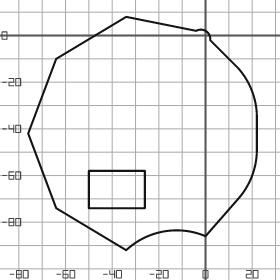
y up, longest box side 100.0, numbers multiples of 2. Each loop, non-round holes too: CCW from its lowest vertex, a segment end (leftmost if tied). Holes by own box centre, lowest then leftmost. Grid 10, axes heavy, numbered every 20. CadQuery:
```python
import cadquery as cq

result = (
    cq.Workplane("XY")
    .moveTo(-34.0, -92.0)
    .threePointArc((-18.0, -84.0), (0.0, -86.0))
    .lineTo(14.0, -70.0)
    .threePointArc((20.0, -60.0), (22.0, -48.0))
    .lineTo(22.0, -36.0)
    .threePointArc((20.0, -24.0), (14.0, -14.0))
    .lineTo(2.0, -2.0)
    .threePointArc((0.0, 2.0), (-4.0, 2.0))
    .lineTo(-34.0, 8.0)
    .lineTo(-64.0, -10.0)
    .lineTo(-76.0, -42.0)
    .lineTo(-64.0, -74.0)
    .close()
    .moveTo(-50.0, -74.0)
    .lineTo(-26.0, -74.0)
    .lineTo(-26.0, -58.0)
    .lineTo(-50.0, -58.0)
    .close()
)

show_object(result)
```